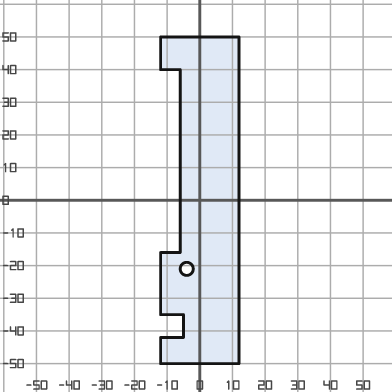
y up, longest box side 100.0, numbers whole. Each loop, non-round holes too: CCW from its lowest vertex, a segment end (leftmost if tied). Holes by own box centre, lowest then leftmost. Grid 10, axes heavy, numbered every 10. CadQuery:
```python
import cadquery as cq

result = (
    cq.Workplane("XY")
    .moveTo(-12.0, -50.0)
    .lineTo(12.0, -50.0)
    .lineTo(12.0, 50.0)
    .lineTo(-12.0, 50.0)
    .lineTo(-12.0, 40.0)
    .lineTo(-6.0, 40.0)
    .lineTo(-6.0, -16.0)
    .lineTo(-12.0, -16.0)
    .lineTo(-12.0, -35.0)
    .lineTo(-5.0, -35.0)
    .lineTo(-5.0, -42.0)
    .lineTo(-12.0, -42.0)
    .close()
    .moveTo(-4.0, -21.0)
    .circle(2.0)
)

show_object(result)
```